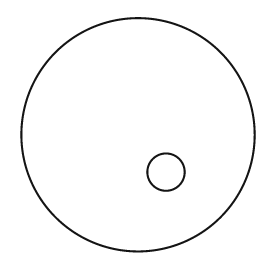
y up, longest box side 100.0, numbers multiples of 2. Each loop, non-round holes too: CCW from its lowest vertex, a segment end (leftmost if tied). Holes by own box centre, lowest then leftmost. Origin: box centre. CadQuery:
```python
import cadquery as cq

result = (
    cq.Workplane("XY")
    .moveTo(0.0, 0.0)
    .circle(50.0)
    .moveTo(12.0, -16.0)
    .circle(8.0)
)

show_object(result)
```